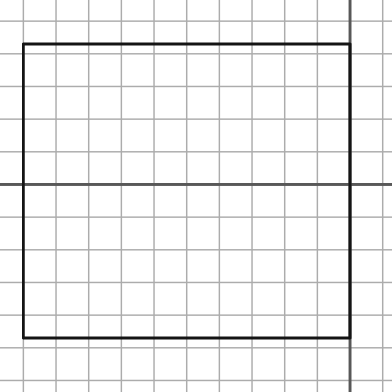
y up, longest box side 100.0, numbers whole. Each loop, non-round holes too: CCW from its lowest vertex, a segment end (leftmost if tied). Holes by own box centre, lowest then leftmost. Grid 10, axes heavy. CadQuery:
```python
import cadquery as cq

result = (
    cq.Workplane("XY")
    .moveTo(-100.0, -47.0)
    .lineTo(0.0, -47.0)
    .lineTo(0.0, 43.0)
    .lineTo(-100.0, 43.0)
    .close()
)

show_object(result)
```